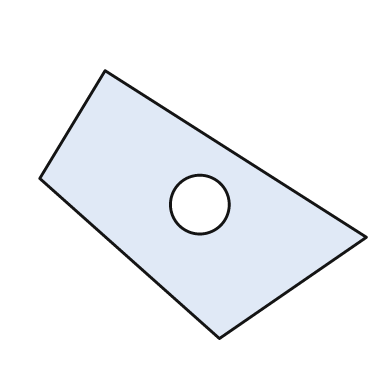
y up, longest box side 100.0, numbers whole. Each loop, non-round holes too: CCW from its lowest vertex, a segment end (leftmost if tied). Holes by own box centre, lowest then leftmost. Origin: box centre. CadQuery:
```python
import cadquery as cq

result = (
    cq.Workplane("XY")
    .moveTo(5.0, -41.0)
    .lineTo(50.0, -10.0)
    .lineTo(-30.0, 41.0)
    .lineTo(-50.0, 8.0)
    .close()
    .moveTo(-1.0, 0.0)
    .circle(9.0)
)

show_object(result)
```